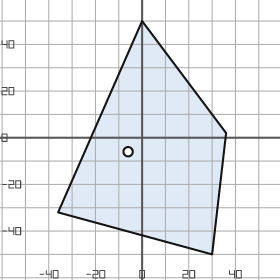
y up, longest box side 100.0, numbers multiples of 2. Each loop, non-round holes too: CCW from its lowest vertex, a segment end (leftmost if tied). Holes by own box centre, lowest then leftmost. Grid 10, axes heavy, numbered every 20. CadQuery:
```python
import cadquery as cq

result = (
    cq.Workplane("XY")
    .moveTo(30.0, -50.0)
    .lineTo(36.0, 2.0)
    .lineTo(0.0, 50.0)
    .lineTo(-36.0, -32.0)
    .close()
    .moveTo(-6.0, -6.0)
    .circle(2.0)
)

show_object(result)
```